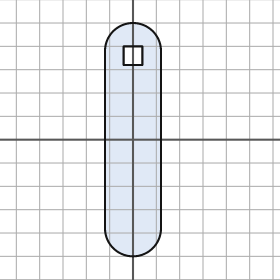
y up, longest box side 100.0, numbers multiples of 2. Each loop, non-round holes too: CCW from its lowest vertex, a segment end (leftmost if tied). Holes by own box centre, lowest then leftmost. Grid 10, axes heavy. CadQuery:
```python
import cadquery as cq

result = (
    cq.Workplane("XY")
    .moveTo(-12.0, -38.0)
    .threePointArc((0.0, -50.0), (12.0, -38.0))
    .lineTo(12.0, 38.0)
    .threePointArc((0.0, 50.0), (-12.0, 38.0))
    .close()
    .moveTo(-4.0, 32.0)
    .lineTo(4.0, 32.0)
    .lineTo(4.0, 40.0)
    .lineTo(-4.0, 40.0)
    .close()
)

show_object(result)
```